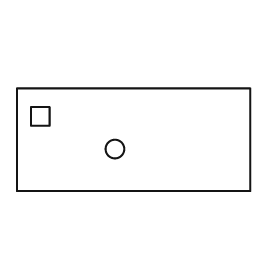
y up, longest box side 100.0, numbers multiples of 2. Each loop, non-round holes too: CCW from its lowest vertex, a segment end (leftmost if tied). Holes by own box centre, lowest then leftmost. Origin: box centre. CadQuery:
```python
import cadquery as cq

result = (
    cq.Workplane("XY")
    .moveTo(-50.0, -22.0)
    .lineTo(50.0, -22.0)
    .lineTo(50.0, 22.0)
    .lineTo(-50.0, 22.0)
    .close()
    .moveTo(-8.0, -4.0)
    .circle(4.0)
    .moveTo(-44.0, 6.0)
    .lineTo(-36.0, 6.0)
    .lineTo(-36.0, 14.0)
    .lineTo(-44.0, 14.0)
    .close()
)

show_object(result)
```